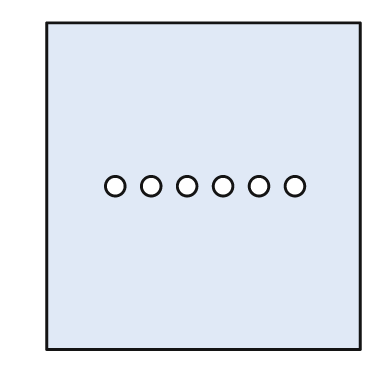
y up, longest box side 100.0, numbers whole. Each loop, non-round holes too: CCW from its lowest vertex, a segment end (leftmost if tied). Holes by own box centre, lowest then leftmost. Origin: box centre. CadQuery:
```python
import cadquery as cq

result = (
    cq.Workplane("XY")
    .moveTo(-48.0, -50.0)
    .lineTo(48.0, -50.0)
    .lineTo(48.0, 50.0)
    .lineTo(-48.0, 50.0)
    .close()
    .moveTo(-27.0, 0.0)
    .circle(3.0)
    .moveTo(-16.0, 0.0)
    .circle(3.0)
    .moveTo(-5.0, 0.0)
    .circle(3.0)
    .moveTo(6.0, 0.0)
    .circle(3.0)
    .moveTo(17.0, 0.0)
    .circle(3.0)
    .moveTo(28.0, 0.0)
    .circle(3.0)
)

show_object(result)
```